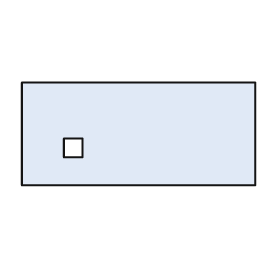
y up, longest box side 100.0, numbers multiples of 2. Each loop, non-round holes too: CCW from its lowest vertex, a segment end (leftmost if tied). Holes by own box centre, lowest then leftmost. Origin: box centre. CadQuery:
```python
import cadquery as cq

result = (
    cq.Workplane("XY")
    .moveTo(-50.0, -22.0)
    .lineTo(50.0, -22.0)
    .lineTo(50.0, 22.0)
    .lineTo(-50.0, 22.0)
    .close()
    .moveTo(-32.0, -10.0)
    .lineTo(-24.0, -10.0)
    .lineTo(-24.0, -2.0)
    .lineTo(-32.0, -2.0)
    .close()
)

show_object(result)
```